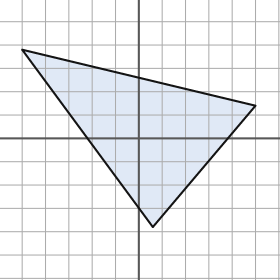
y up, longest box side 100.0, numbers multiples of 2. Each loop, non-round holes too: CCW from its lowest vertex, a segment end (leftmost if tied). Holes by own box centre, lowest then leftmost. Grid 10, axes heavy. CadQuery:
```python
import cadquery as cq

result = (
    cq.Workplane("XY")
    .moveTo(6.0, -38.0)
    .lineTo(50.0, 14.0)
    .lineTo(-50.0, 38.0)
    .close()
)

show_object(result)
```